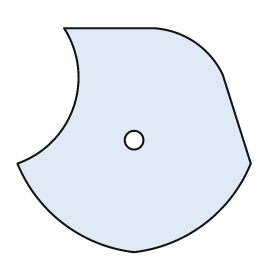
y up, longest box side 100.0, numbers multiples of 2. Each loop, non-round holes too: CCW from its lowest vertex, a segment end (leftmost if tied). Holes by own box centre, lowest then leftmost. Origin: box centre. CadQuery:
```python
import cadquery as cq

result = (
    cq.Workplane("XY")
    .moveTo(0.0, -48.0)
    .threePointArc((30.0, -36.0), (50.0, -10.0))
    .lineTo(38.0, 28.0)
    .threePointArc((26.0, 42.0), (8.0, 48.0))
    .lineTo(-30.0, 48.0)
    .threePointArc((-26.0, 14.0), (-50.0, -10.0))
    .threePointArc((-30.0, -36.0), (0.0, -48.0))
    .close()
    .moveTo(0.0, 0.0)
    .circle(4.0)
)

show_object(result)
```